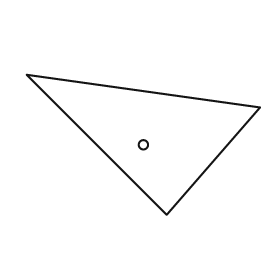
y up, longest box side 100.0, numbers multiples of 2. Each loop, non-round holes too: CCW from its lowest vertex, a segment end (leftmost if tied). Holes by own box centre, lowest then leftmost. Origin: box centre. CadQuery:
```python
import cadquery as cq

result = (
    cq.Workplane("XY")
    .moveTo(10.0, -30.0)
    .lineTo(50.0, 16.0)
    .lineTo(-50.0, 30.0)
    .close()
    .moveTo(0.0, 0.0)
    .circle(2.0)
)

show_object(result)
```